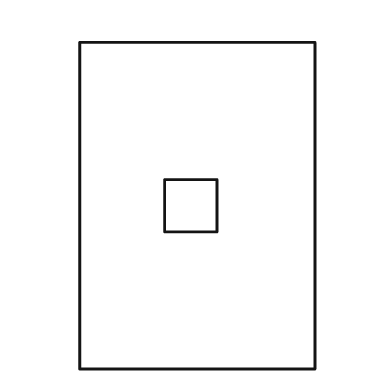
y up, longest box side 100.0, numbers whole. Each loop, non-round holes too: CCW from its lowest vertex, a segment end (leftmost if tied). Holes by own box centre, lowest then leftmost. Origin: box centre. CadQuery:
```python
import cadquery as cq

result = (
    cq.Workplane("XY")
    .moveTo(-36.0, -50.0)
    .lineTo(36.0, -50.0)
    .lineTo(36.0, 50.0)
    .lineTo(-36.0, 50.0)
    .close()
    .moveTo(-10.0, -8.0)
    .lineTo(6.0, -8.0)
    .lineTo(6.0, 8.0)
    .lineTo(-10.0, 8.0)
    .close()
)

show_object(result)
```